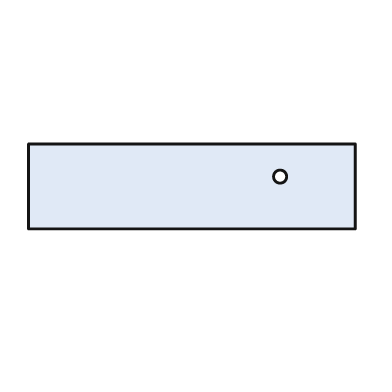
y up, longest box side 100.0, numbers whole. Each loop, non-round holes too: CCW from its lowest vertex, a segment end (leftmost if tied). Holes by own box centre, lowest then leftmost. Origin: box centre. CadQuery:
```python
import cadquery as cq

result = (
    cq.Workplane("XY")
    .moveTo(-50.0, -13.0)
    .lineTo(50.0, -13.0)
    .lineTo(50.0, 13.0)
    .lineTo(-50.0, 13.0)
    .close()
    .moveTo(27.0, 3.0)
    .circle(2.0)
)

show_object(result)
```